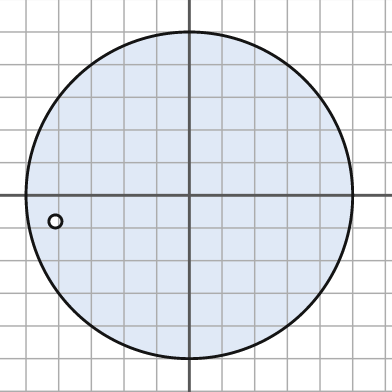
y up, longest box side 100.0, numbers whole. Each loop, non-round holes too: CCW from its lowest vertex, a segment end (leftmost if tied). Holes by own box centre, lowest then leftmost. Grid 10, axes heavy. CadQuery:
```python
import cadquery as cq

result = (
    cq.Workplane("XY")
    .moveTo(0.0, 0.0)
    .circle(50.0)
    .moveTo(-41.0, -8.0)
    .circle(2.0)
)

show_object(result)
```